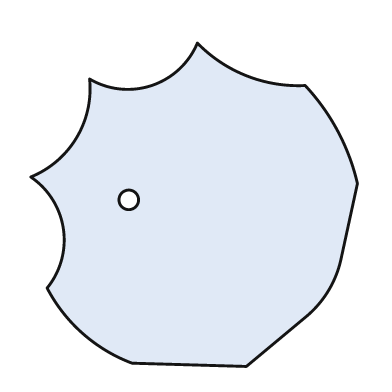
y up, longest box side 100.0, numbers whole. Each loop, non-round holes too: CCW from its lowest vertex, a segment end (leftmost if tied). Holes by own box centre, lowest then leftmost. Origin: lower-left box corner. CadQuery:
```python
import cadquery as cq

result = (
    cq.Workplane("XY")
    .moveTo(66.0, 0.0)
    .lineTo(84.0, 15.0)
    .threePointArc((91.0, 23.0), (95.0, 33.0))
    .lineTo(100.0, 56.0)
    .threePointArc((94.0, 72.0), (84.0, 86.0))
    .threePointArc((66.0, 89.0), (51.0, 99.0))
    .threePointArc((37.0, 86.0), (18.0, 88.0))
    .threePointArc((14.0, 70.0), (0.0, 58.0))
    .threePointArc((10.0, 42.0), (5.0, 24.0))
    .threePointArc((16.0, 10.0), (31.0, 1.0))
    .close()
    .moveTo(30.0, 51.0)
    .circle(3.0)
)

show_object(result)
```